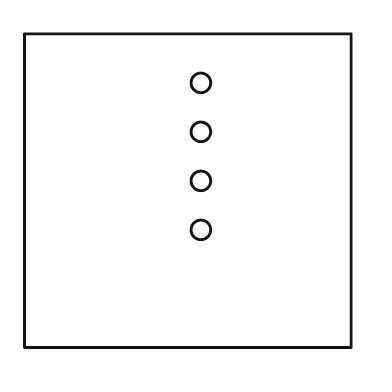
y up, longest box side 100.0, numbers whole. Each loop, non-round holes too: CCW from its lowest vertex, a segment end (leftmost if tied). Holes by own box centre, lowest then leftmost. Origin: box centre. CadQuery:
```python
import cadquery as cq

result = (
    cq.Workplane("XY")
    .moveTo(-50.0, -48.0)
    .lineTo(50.0, -48.0)
    .lineTo(50.0, 48.0)
    .lineTo(-50.0, 48.0)
    .close()
    .moveTo(4.0, -12.0)
    .circle(3.0)
    .moveTo(4.0, 3.0)
    .circle(3.0)
    .moveTo(4.0, 18.0)
    .circle(3.0)
    .moveTo(4.0, 33.0)
    .circle(3.0)
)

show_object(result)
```